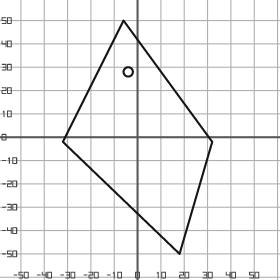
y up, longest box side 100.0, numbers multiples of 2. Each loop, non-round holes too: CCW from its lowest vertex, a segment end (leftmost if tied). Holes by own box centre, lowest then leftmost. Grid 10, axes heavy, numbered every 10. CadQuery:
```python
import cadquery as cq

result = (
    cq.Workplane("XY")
    .moveTo(18.0, -50.0)
    .lineTo(32.0, -2.0)
    .lineTo(-6.0, 50.0)
    .lineTo(-32.0, -2.0)
    .close()
    .moveTo(-4.0, 28.0)
    .circle(2.0)
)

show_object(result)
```